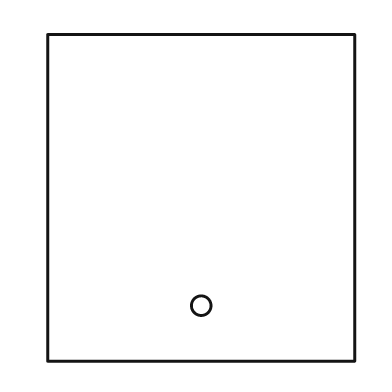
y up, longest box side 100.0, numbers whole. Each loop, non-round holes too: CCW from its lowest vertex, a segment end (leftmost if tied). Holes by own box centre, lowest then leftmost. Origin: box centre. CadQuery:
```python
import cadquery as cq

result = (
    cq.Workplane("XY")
    .moveTo(-47.0, -50.0)
    .lineTo(47.0, -50.0)
    .lineTo(47.0, 50.0)
    .lineTo(-47.0, 50.0)
    .close()
    .moveTo(0.0, -33.0)
    .circle(3.0)
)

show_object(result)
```